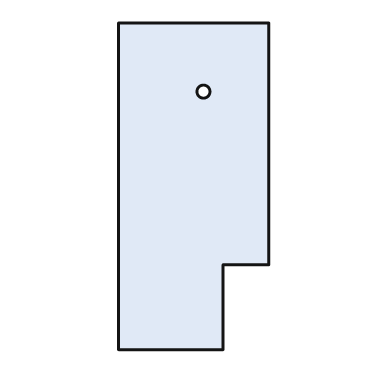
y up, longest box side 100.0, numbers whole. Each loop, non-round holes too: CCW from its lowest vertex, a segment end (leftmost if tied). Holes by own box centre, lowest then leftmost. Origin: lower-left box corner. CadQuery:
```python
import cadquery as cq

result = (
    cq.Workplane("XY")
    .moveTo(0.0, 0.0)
    .lineTo(32.0, 0.0)
    .lineTo(32.0, 26.0)
    .lineTo(46.0, 26.0)
    .lineTo(46.0, 100.0)
    .lineTo(0.0, 100.0)
    .close()
    .moveTo(26.0, 79.0)
    .circle(2.0)
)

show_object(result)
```